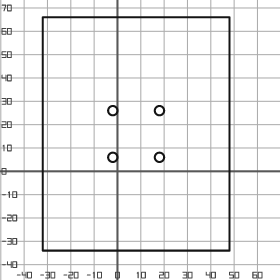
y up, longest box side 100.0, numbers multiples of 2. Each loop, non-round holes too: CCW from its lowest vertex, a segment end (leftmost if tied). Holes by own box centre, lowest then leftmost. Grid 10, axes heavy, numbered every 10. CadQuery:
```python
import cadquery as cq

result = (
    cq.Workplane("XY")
    .moveTo(-32.0, -34.0)
    .lineTo(48.0, -34.0)
    .lineTo(48.0, 66.0)
    .lineTo(-32.0, 66.0)
    .close()
    .moveTo(-2.0, 6.0)
    .circle(2.0)
    .moveTo(18.0, 6.0)
    .circle(2.0)
    .moveTo(-2.0, 26.0)
    .circle(2.0)
    .moveTo(18.0, 26.0)
    .circle(2.0)
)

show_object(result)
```